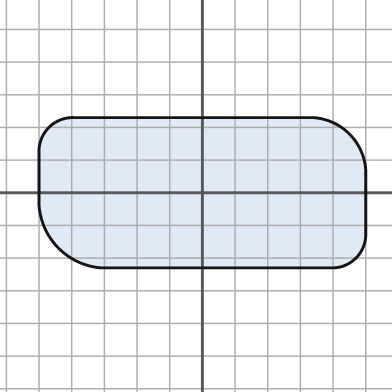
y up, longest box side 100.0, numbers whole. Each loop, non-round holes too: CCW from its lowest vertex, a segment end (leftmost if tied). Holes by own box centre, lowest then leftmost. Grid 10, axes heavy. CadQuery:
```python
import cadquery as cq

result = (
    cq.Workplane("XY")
    .moveTo(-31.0, -23.0)
    .lineTo(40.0, -23.0)
    .threePointArc((47.0, -20.0), (50.0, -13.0))
    .lineTo(50.0, 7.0)
    .threePointArc((45.0, 18.0), (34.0, 23.0))
    .lineTo(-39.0, 23.0)
    .threePointArc((-47.0, 20.0), (-50.0, 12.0))
    .lineTo(-50.0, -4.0)
    .threePointArc((-44.0, -17.0), (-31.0, -23.0))
    .close()
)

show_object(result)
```